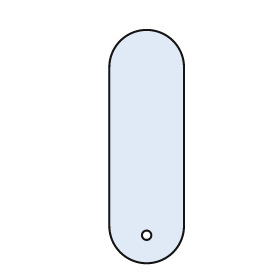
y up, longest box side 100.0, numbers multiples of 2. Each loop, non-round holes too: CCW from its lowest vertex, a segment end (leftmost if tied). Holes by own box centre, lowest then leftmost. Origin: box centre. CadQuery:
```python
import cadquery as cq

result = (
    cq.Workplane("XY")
    .moveTo(-16.0, -34.0)
    .threePointArc((0.0, -50.0), (16.0, -34.0))
    .lineTo(16.0, 34.0)
    .threePointArc((0.0, 50.0), (-16.0, 34.0))
    .close()
    .moveTo(0.0, -38.0)
    .circle(2.0)
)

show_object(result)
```